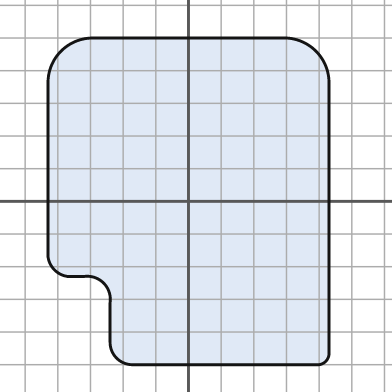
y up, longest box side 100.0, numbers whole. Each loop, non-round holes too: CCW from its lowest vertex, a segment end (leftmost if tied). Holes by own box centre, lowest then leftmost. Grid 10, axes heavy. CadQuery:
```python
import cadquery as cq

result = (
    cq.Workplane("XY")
    .moveTo(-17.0, -50.0)
    .lineTo(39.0, -50.0)
    .threePointArc((42.0, -49.0), (43.0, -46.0))
    .lineTo(43.0, 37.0)
    .threePointArc((39.0, 46.0), (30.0, 50.0))
    .lineTo(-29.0, 50.0)
    .threePointArc((-39.0, 46.0), (-43.0, 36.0))
    .lineTo(-43.0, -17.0)
    .threePointArc((-41.0, -21.0), (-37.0, -23.0))
    .lineTo(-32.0, -23.0)
    .threePointArc((-26.0, -25.0), (-24.0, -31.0))
    .lineTo(-24.0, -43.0)
    .threePointArc((-22.0, -48.0), (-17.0, -50.0))
    .close()
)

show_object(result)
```